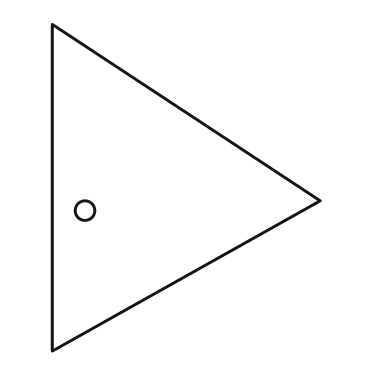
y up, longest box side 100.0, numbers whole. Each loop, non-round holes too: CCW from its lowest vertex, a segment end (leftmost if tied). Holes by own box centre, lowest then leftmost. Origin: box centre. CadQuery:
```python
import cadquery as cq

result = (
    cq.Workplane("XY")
    .moveTo(-41.0, -50.0)
    .lineTo(41.0, -4.0)
    .lineTo(-41.0, 50.0)
    .close()
    .moveTo(-31.0, -7.0)
    .circle(3.0)
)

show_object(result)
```